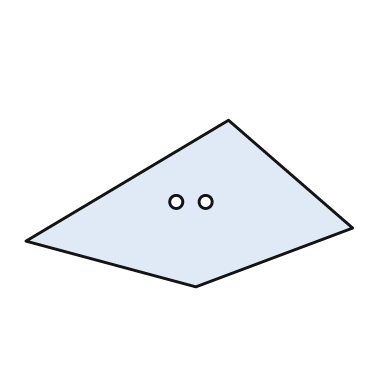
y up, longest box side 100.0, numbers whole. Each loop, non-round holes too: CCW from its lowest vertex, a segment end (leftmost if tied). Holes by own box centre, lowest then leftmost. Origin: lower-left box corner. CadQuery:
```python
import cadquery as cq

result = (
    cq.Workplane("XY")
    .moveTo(52.0, 0.0)
    .lineTo(100.0, 18.0)
    .lineTo(62.0, 51.0)
    .lineTo(0.0, 14.0)
    .close()
    .moveTo(46.0, 26.0)
    .circle(2.0)
    .moveTo(55.0, 26.0)
    .circle(2.0)
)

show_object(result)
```